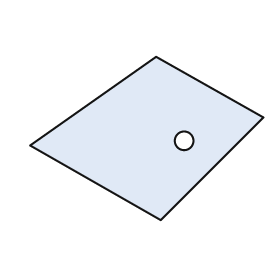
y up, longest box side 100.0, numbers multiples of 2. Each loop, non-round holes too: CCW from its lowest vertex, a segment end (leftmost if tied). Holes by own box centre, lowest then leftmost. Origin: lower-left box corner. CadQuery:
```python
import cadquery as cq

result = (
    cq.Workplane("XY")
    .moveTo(56.0, 0.0)
    .lineTo(100.0, 44.0)
    .lineTo(54.0, 70.0)
    .lineTo(0.0, 32.0)
    .close()
    .moveTo(66.0, 34.0)
    .circle(4.0)
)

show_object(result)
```